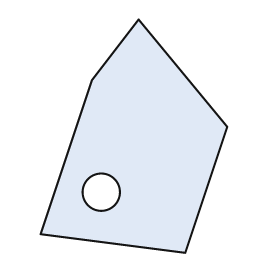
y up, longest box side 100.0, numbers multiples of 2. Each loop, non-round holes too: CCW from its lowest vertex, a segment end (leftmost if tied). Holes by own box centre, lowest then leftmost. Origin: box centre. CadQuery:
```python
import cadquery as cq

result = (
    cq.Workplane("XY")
    .moveTo(22.0, -50.0)
    .lineTo(40.0, 4.0)
    .lineTo(2.0, 50.0)
    .lineTo(-18.0, 24.0)
    .lineTo(-40.0, -42.0)
    .close()
    .moveTo(-14.0, -24.0)
    .circle(8.0)
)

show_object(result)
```